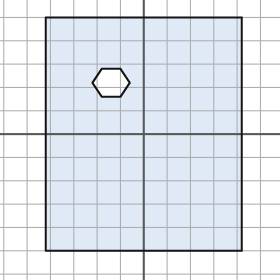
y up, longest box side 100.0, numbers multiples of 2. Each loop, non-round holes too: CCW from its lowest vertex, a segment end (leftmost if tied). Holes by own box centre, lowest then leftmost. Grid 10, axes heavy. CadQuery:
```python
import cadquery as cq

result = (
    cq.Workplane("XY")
    .moveTo(-42.0, -50.0)
    .lineTo(42.0, -50.0)
    .lineTo(42.0, 50.0)
    .lineTo(-42.0, 50.0)
    .close()
    .moveTo(-18.0, 16.0)
    .lineTo(-10.0, 16.0)
    .lineTo(-6.0, 22.0)
    .lineTo(-10.0, 28.0)
    .lineTo(-18.0, 28.0)
    .lineTo(-22.0, 22.0)
    .close()
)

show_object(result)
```